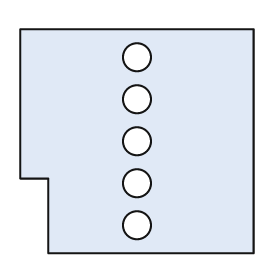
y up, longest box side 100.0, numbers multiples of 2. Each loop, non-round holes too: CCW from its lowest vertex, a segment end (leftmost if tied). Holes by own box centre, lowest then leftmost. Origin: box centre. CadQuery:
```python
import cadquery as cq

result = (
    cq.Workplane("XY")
    .moveTo(-38.0, -48.0)
    .lineTo(50.0, -48.0)
    .lineTo(50.0, 48.0)
    .lineTo(-50.0, 48.0)
    .lineTo(-50.0, -16.0)
    .lineTo(-38.0, -16.0)
    .close()
    .moveTo(0.0, -36.0)
    .circle(6.0)
    .moveTo(0.0, -18.0)
    .circle(6.0)
    .moveTo(0.0, 0.0)
    .circle(6.0)
    .moveTo(0.0, 18.0)
    .circle(6.0)
    .moveTo(0.0, 36.0)
    .circle(6.0)
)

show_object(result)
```